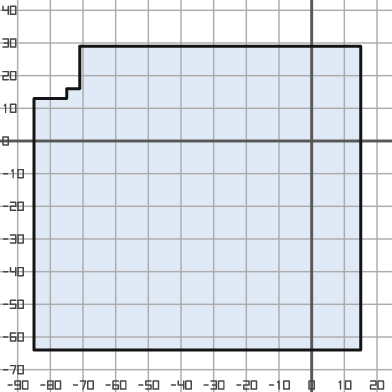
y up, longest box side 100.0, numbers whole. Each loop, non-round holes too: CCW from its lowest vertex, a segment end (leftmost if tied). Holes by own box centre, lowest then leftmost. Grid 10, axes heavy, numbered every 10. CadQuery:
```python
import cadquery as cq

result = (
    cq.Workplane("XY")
    .moveTo(-85.0, -64.0)
    .lineTo(15.0, -64.0)
    .lineTo(15.0, 29.0)
    .lineTo(-71.0, 29.0)
    .lineTo(-71.0, 16.0)
    .lineTo(-75.0, 16.0)
    .lineTo(-75.0, 13.0)
    .lineTo(-85.0, 13.0)
    .close()
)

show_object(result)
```